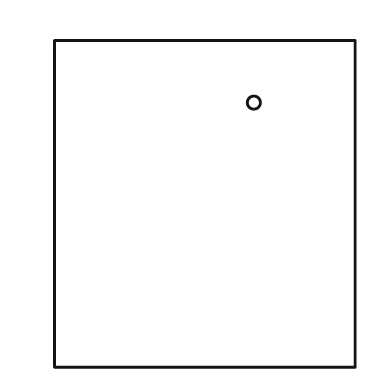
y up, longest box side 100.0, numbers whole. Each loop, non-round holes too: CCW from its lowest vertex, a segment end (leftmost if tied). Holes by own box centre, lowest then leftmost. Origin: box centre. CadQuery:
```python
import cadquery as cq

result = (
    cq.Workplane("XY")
    .moveTo(-46.0, -50.0)
    .lineTo(46.0, -50.0)
    .lineTo(46.0, 50.0)
    .lineTo(-46.0, 50.0)
    .close()
    .moveTo(15.0, 31.0)
    .circle(2.0)
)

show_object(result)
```